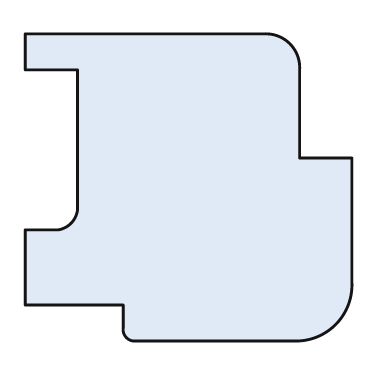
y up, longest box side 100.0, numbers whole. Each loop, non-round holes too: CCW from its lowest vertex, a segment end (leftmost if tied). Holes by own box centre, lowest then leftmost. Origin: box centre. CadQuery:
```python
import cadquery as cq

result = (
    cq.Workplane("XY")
    .moveTo(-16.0, -47.0)
    .lineTo(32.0, -47.0)
    .threePointArc((45.0, -42.0), (50.0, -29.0))
    .lineTo(50.0, 9.0)
    .lineTo(34.0, 9.0)
    .lineTo(34.0, 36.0)
    .threePointArc((31.0, 44.0), (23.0, 47.0))
    .lineTo(-50.0, 47.0)
    .lineTo(-50.0, 36.0)
    .lineTo(-34.0, 36.0)
    .lineTo(-34.0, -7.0)
    .threePointArc((-36.0, -11.0), (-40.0, -13.0))
    .lineTo(-50.0, -13.0)
    .lineTo(-50.0, -36.0)
    .lineTo(-20.0, -36.0)
    .lineTo(-20.0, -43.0)
    .threePointArc((-19.0, -46.0), (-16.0, -47.0))
    .close()
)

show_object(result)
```